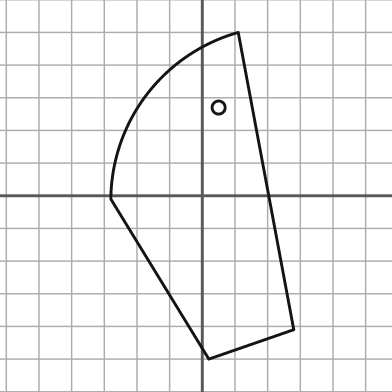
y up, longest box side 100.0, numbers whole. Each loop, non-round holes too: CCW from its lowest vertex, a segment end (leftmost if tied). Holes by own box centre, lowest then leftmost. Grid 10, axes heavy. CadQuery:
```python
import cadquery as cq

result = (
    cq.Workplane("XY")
    .moveTo(2.0, -50.0)
    .lineTo(28.0, -41.0)
    .lineTo(11.0, 50.0)
    .threePointArc((-17.0, 31.0), (-28.0, -1.0))
    .close()
    .moveTo(5.0, 27.0)
    .circle(2.0)
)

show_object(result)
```